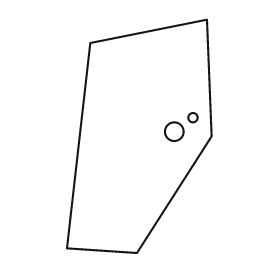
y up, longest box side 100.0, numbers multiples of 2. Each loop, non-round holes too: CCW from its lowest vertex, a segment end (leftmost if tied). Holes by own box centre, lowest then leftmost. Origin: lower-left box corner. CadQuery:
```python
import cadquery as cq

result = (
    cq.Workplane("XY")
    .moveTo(30.0, 0.0)
    .lineTo(62.0, 50.0)
    .lineTo(60.0, 100.0)
    .lineTo(10.0, 90.0)
    .lineTo(0.0, 2.0)
    .close()
    .moveTo(46.0, 52.0)
    .circle(4.0)
    .moveTo(54.0, 58.0)
    .circle(2.0)
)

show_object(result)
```